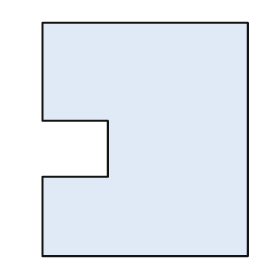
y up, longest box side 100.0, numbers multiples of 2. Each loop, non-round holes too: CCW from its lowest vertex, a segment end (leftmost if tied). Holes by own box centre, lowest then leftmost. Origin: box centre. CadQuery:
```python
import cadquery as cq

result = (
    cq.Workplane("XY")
    .moveTo(-44.0, -50.0)
    .lineTo(44.0, -50.0)
    .lineTo(44.0, 50.0)
    .lineTo(-44.0, 50.0)
    .lineTo(-44.0, 8.0)
    .lineTo(-16.0, 8.0)
    .lineTo(-16.0, -16.0)
    .lineTo(-44.0, -16.0)
    .close()
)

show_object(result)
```